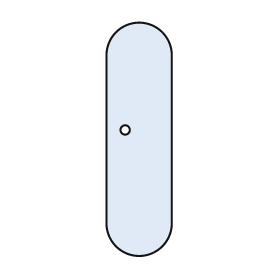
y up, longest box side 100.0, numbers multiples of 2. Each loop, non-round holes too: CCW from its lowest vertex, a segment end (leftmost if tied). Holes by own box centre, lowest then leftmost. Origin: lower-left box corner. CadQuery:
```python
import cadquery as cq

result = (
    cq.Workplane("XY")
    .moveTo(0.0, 14.0)
    .threePointArc((14.0, 0.0), (28.0, 14.0))
    .lineTo(28.0, 86.0)
    .threePointArc((14.0, 100.0), (0.0, 86.0))
    .close()
    .moveTo(8.0, 54.0)
    .circle(2.0)
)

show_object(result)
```